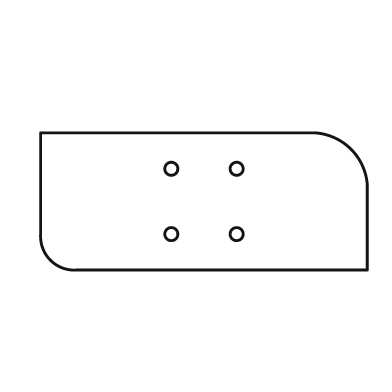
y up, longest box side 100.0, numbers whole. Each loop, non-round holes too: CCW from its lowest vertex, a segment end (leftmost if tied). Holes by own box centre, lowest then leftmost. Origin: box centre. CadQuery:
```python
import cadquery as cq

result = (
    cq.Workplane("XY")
    .moveTo(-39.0, -21.0)
    .lineTo(50.0, -21.0)
    .lineTo(50.0, 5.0)
    .threePointArc((45.0, 16.0), (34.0, 21.0))
    .lineTo(-50.0, 21.0)
    .lineTo(-50.0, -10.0)
    .threePointArc((-47.0, -18.0), (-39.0, -21.0))
    .close()
    .moveTo(-10.0, -10.0)
    .circle(2.0)
    .moveTo(10.0, -10.0)
    .circle(2.0)
    .moveTo(-10.0, 10.0)
    .circle(2.0)
    .moveTo(10.0, 10.0)
    .circle(2.0)
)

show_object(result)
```